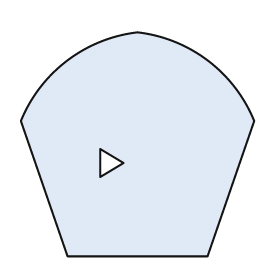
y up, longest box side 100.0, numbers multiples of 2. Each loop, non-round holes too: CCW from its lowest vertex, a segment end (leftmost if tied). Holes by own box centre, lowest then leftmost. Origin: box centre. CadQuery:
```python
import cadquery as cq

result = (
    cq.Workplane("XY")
    .moveTo(-30.0, -48.0)
    .lineTo(30.0, -48.0)
    .lineTo(50.0, 10.0)
    .threePointArc((30.0, 36.0), (0.0, 48.0))
    .threePointArc((-30.0, 36.0), (-50.0, 10.0))
    .close()
    .moveTo(-16.0, -14.0)
    .lineTo(-6.0, -8.0)
    .lineTo(-16.0, -2.0)
    .close()
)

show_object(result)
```